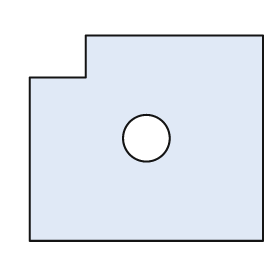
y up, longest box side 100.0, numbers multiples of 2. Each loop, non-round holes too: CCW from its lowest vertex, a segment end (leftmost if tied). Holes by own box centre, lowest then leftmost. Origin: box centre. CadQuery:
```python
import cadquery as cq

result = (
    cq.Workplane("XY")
    .moveTo(-50.0, -44.0)
    .lineTo(50.0, -44.0)
    .lineTo(50.0, 44.0)
    .lineTo(-26.0, 44.0)
    .lineTo(-26.0, 26.0)
    .lineTo(-50.0, 26.0)
    .close()
    .moveTo(0.0, 0.0)
    .circle(10.0)
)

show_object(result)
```